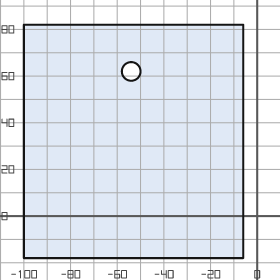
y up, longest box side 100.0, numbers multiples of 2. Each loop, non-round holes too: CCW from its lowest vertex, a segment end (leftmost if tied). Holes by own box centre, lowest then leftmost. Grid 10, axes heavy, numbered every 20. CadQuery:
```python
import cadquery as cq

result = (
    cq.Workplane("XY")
    .moveTo(-100.0, -18.0)
    .lineTo(-6.0, -18.0)
    .lineTo(-6.0, 82.0)
    .lineTo(-100.0, 82.0)
    .close()
    .moveTo(-54.0, 62.0)
    .circle(4.0)
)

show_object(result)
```